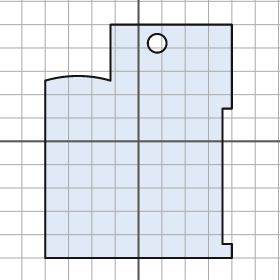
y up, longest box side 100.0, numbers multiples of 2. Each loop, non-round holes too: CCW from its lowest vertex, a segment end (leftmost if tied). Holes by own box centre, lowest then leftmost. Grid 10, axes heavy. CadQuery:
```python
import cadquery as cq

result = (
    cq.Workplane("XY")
    .moveTo(-40.0, -50.0)
    .lineTo(40.0, -50.0)
    .lineTo(40.0, -44.0)
    .lineTo(36.0, -44.0)
    .lineTo(36.0, 14.0)
    .lineTo(40.0, 14.0)
    .lineTo(40.0, 50.0)
    .lineTo(-12.0, 50.0)
    .lineTo(-12.0, 26.0)
    .threePointArc((-26.0, 28.0), (-40.0, 26.0))
    .close()
    .moveTo(8.0, 42.0)
    .circle(4.0)
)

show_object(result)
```